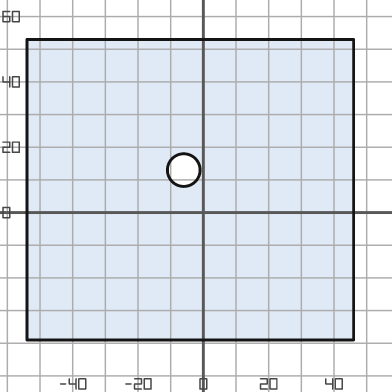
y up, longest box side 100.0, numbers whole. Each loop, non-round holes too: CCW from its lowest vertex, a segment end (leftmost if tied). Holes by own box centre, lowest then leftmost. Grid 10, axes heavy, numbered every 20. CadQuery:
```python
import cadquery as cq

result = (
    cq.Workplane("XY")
    .moveTo(-54.0, -39.0)
    .lineTo(46.0, -39.0)
    .lineTo(46.0, 53.0)
    .lineTo(-54.0, 53.0)
    .close()
    .moveTo(-6.0, 13.0)
    .circle(5.0)
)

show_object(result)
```